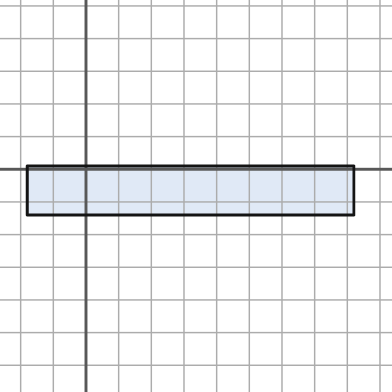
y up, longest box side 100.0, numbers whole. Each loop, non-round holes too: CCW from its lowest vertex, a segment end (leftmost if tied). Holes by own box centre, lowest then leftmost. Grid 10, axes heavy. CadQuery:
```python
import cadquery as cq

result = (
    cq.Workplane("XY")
    .moveTo(-18.0, -14.0)
    .lineTo(82.0, -14.0)
    .lineTo(82.0, 1.0)
    .lineTo(-18.0, 1.0)
    .close()
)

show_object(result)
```